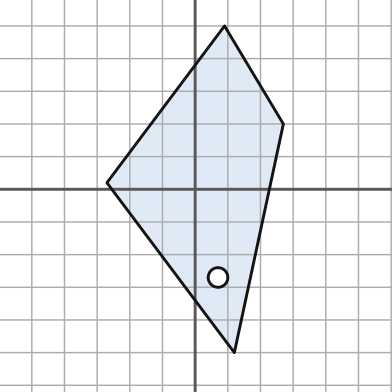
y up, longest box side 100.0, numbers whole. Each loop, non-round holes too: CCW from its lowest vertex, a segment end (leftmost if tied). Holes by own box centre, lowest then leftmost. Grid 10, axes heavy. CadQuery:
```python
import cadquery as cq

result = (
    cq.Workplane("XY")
    .moveTo(12.0, -50.0)
    .lineTo(27.0, 20.0)
    .lineTo(9.0, 50.0)
    .lineTo(-27.0, 2.0)
    .close()
    .moveTo(7.0, -27.0)
    .circle(3.0)
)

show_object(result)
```